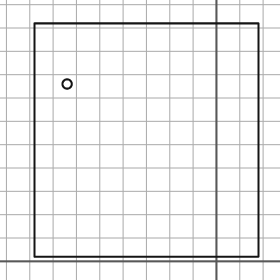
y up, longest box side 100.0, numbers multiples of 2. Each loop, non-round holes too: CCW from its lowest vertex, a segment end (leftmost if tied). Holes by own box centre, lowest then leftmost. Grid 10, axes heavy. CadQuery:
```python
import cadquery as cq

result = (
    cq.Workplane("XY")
    .moveTo(-78.0, 2.0)
    .lineTo(18.0, 2.0)
    .lineTo(18.0, 102.0)
    .lineTo(-78.0, 102.0)
    .close()
    .moveTo(-64.0, 76.0)
    .circle(2.0)
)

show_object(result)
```